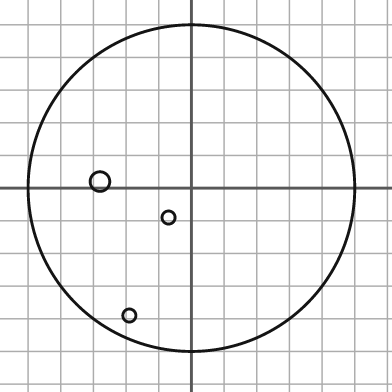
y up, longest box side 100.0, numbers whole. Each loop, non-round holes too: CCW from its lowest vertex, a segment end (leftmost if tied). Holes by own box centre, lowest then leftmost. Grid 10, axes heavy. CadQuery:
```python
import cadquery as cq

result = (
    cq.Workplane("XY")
    .moveTo(0.0, 0.0)
    .circle(50.0)
    .moveTo(-19.0, -39.0)
    .circle(2.0)
    .moveTo(-7.0, -9.0)
    .circle(2.0)
    .moveTo(-28.0, 2.0)
    .circle(3.0)
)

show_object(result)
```